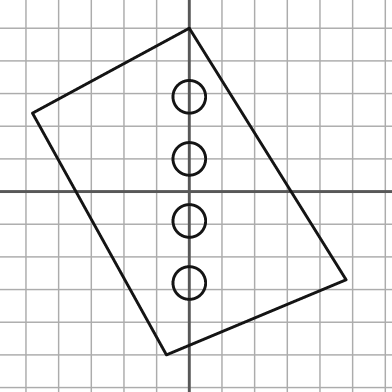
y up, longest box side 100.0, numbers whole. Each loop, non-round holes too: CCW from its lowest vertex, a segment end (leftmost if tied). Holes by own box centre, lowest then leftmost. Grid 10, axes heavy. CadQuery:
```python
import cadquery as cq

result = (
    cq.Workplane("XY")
    .moveTo(-7.0, -50.0)
    .lineTo(48.0, -27.0)
    .lineTo(0.0, 50.0)
    .lineTo(-48.0, 24.0)
    .close()
    .moveTo(0.0, -28.0)
    .circle(5.0)
    .moveTo(0.0, -9.0)
    .circle(5.0)
    .moveTo(0.0, 10.0)
    .circle(5.0)
    .moveTo(0.0, 29.0)
    .circle(5.0)
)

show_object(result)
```